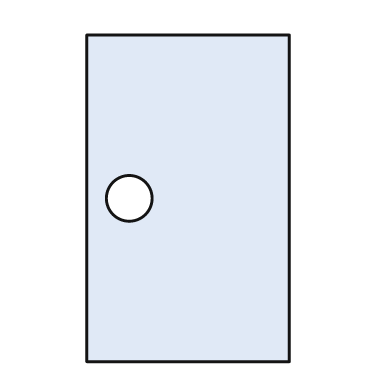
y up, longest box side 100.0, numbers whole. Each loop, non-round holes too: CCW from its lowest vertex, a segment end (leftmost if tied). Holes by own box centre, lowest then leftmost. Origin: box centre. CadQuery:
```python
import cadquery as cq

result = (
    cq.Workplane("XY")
    .moveTo(-31.0, -50.0)
    .lineTo(31.0, -50.0)
    .lineTo(31.0, 50.0)
    .lineTo(-31.0, 50.0)
    .close()
    .moveTo(-18.0, 0.0)
    .circle(7.0)
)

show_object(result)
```